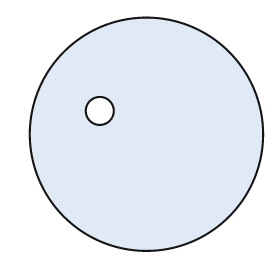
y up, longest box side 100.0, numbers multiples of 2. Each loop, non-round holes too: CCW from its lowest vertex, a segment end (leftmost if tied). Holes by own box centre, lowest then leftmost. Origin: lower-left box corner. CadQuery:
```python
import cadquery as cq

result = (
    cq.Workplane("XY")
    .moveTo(50.0, 50.0)
    .circle(50.0)
    .moveTo(30.0, 60.0)
    .circle(6.0)
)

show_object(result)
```